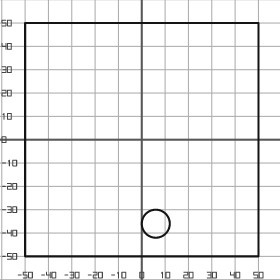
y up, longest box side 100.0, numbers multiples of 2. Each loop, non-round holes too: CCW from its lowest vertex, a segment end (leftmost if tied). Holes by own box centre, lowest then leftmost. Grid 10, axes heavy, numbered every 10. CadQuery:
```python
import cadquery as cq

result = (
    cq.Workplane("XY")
    .moveTo(-50.0, -50.0)
    .lineTo(50.0, -50.0)
    .lineTo(50.0, 50.0)
    .lineTo(-50.0, 50.0)
    .close()
    .moveTo(6.0, -36.0)
    .circle(6.0)
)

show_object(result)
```